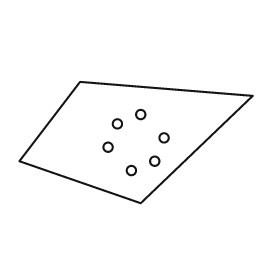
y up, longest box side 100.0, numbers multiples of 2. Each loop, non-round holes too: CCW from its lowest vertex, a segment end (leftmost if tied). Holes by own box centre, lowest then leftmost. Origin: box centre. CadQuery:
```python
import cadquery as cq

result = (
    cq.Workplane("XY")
    .moveTo(2.0, -26.0)
    .lineTo(50.0, 20.0)
    .lineTo(-24.0, 26.0)
    .lineTo(-50.0, -8.0)
    .close()
    .moveTo(-2.0, -12.0)
    .circle(2.0)
    .moveTo(8.0, -8.0)
    .circle(2.0)
    .moveTo(-12.0, -2.0)
    .circle(2.0)
    .moveTo(12.0, 2.0)
    .circle(2.0)
    .moveTo(-8.0, 8.0)
    .circle(2.0)
    .moveTo(2.0, 12.0)
    .circle(2.0)
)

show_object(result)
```